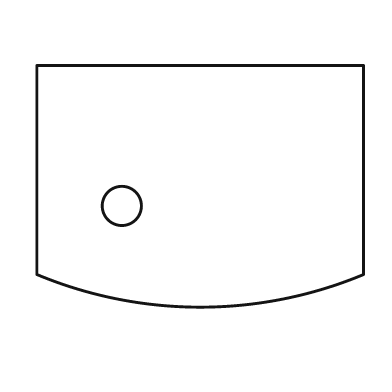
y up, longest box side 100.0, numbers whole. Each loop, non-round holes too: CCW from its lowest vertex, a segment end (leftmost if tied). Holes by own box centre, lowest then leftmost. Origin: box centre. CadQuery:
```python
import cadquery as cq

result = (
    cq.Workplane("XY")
    .moveTo(-50.0, -27.0)
    .threePointArc((0.0, -37.0), (50.0, -27.0))
    .lineTo(50.0, 37.0)
    .lineTo(-50.0, 37.0)
    .close()
    .moveTo(-24.0, -6.0)
    .circle(6.0)
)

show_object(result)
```